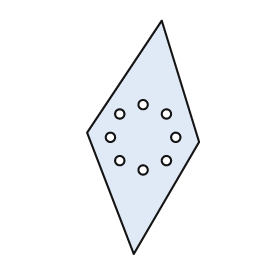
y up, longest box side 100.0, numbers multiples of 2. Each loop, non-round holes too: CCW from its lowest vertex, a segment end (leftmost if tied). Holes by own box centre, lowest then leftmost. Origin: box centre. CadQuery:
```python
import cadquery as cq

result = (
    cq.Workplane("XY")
    .moveTo(-4.0, -50.0)
    .lineTo(24.0, -2.0)
    .lineTo(8.0, 50.0)
    .lineTo(-24.0, 2.0)
    .close()
    .moveTo(0.0, -14.0)
    .circle(2.0)
    .moveTo(-10.0, -10.0)
    .circle(2.0)
    .moveTo(10.0, -10.0)
    .circle(2.0)
    .moveTo(-14.0, 0.0)
    .circle(2.0)
    .moveTo(14.0, 0.0)
    .circle(2.0)
    .moveTo(-10.0, 10.0)
    .circle(2.0)
    .moveTo(10.0, 10.0)
    .circle(2.0)
    .moveTo(0.0, 14.0)
    .circle(2.0)
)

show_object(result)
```